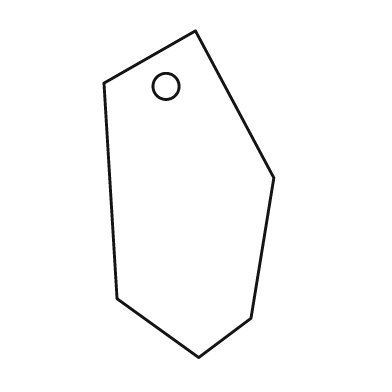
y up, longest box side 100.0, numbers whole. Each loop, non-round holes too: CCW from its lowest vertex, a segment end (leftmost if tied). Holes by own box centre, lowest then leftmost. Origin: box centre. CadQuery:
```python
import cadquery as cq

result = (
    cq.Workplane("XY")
    .moveTo(3.0, -50.0)
    .lineTo(19.0, -38.0)
    .lineTo(26.0, 5.0)
    .lineTo(2.0, 50.0)
    .lineTo(-26.0, 34.0)
    .lineTo(-22.0, -32.0)
    .close()
    .moveTo(-7.0, 33.0)
    .circle(4.0)
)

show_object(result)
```